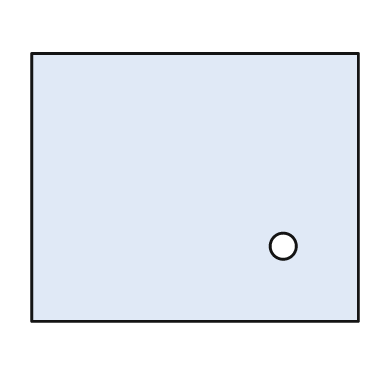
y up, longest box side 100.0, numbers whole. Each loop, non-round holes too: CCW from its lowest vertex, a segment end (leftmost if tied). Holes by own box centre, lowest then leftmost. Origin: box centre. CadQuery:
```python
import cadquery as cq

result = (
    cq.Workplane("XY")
    .moveTo(-50.0, -41.0)
    .lineTo(50.0, -41.0)
    .lineTo(50.0, 41.0)
    .lineTo(-50.0, 41.0)
    .close()
    .moveTo(27.0, -18.0)
    .circle(4.0)
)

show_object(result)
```